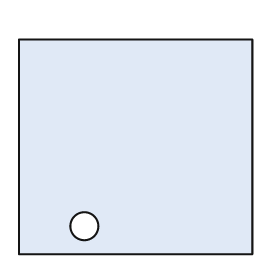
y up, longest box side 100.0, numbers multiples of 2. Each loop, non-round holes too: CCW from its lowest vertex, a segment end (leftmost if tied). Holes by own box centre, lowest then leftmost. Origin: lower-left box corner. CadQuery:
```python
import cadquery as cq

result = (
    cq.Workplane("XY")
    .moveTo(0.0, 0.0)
    .lineTo(100.0, 0.0)
    .lineTo(100.0, 92.0)
    .lineTo(0.0, 92.0)
    .close()
    .moveTo(28.0, 12.0)
    .circle(6.0)
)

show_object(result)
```